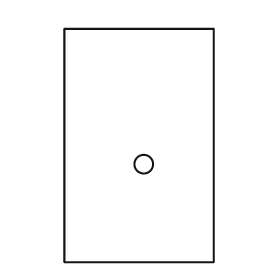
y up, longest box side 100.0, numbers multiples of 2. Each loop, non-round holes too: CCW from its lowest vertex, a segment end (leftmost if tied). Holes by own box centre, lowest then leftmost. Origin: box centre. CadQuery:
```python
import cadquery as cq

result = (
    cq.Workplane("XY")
    .moveTo(-32.0, -50.0)
    .lineTo(32.0, -50.0)
    .lineTo(32.0, 50.0)
    .lineTo(-32.0, 50.0)
    .close()
    .moveTo(2.0, -8.0)
    .circle(4.0)
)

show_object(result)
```